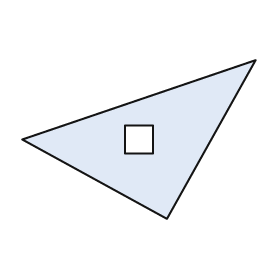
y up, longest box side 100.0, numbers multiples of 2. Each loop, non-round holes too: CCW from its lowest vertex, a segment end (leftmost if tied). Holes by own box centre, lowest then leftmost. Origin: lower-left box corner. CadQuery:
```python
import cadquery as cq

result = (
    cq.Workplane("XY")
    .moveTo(62.0, 0.0)
    .lineTo(100.0, 68.0)
    .lineTo(0.0, 34.0)
    .close()
    .moveTo(44.0, 28.0)
    .lineTo(56.0, 28.0)
    .lineTo(56.0, 40.0)
    .lineTo(44.0, 40.0)
    .close()
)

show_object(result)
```